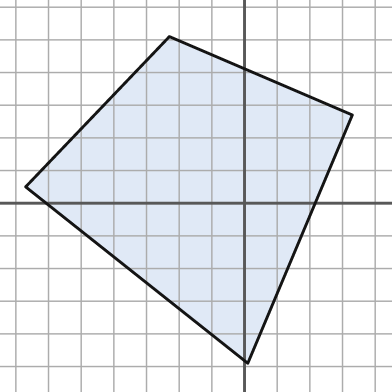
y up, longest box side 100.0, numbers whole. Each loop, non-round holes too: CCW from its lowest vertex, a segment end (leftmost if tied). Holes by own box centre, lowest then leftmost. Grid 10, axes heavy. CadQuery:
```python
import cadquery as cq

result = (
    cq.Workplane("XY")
    .moveTo(1.0, -49.0)
    .lineTo(33.0, 27.0)
    .lineTo(-23.0, 51.0)
    .lineTo(-67.0, 5.0)
    .close()
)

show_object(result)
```